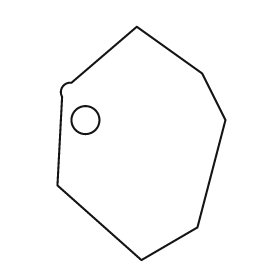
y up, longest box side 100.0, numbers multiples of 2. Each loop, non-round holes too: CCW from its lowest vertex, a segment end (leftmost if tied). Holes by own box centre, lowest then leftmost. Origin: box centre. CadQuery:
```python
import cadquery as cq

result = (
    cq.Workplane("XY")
    .moveTo(0.0, -50.0)
    .lineTo(24.0, -36.0)
    .lineTo(36.0, 10.0)
    .lineTo(26.0, 30.0)
    .lineTo(-2.0, 50.0)
    .lineTo(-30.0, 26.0)
    .threePointArc((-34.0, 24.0), (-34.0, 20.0))
    .lineTo(-36.0, -18.0)
    .close()
    .moveTo(-24.0, 10.0)
    .circle(6.0)
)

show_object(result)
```